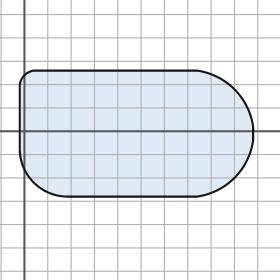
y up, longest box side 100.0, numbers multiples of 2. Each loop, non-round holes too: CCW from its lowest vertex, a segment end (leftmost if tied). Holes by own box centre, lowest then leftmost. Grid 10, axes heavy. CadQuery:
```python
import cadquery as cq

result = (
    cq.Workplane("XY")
    .moveTo(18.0, -28.0)
    .lineTo(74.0, -28.0)
    .threePointArc((90.0, -20.0), (98.0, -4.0))
    .lineTo(98.0, 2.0)
    .threePointArc((90.0, 18.0), (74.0, 26.0))
    .lineTo(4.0, 26.0)
    .threePointArc((0.0, 24.0), (-2.0, 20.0))
    .lineTo(-2.0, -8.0)
    .threePointArc((4.0, -22.0), (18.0, -28.0))
    .close()
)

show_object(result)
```